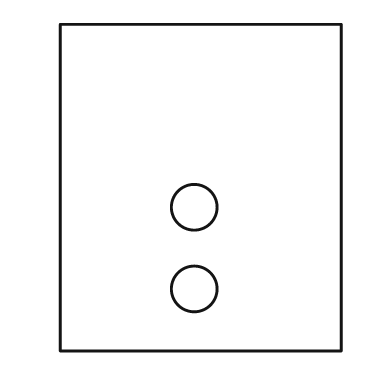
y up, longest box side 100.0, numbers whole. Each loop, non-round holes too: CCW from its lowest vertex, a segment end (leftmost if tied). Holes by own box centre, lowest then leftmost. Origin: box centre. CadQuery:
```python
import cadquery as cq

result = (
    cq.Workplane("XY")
    .moveTo(-43.0, -50.0)
    .lineTo(43.0, -50.0)
    .lineTo(43.0, 50.0)
    .lineTo(-43.0, 50.0)
    .close()
    .moveTo(-2.0, -31.0)
    .circle(7.0)
    .moveTo(-2.0, -6.0)
    .circle(7.0)
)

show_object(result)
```